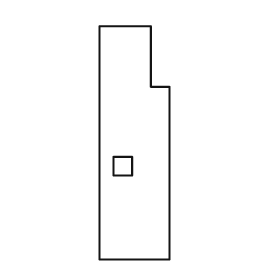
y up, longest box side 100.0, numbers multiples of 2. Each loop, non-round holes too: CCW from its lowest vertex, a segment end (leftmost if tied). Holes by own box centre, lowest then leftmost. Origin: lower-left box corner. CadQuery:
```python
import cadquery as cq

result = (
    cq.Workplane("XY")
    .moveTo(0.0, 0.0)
    .lineTo(30.0, 0.0)
    .lineTo(30.0, 74.0)
    .lineTo(22.0, 74.0)
    .lineTo(22.0, 100.0)
    .lineTo(0.0, 100.0)
    .close()
    .moveTo(6.0, 36.0)
    .lineTo(14.0, 36.0)
    .lineTo(14.0, 44.0)
    .lineTo(6.0, 44.0)
    .close()
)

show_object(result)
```